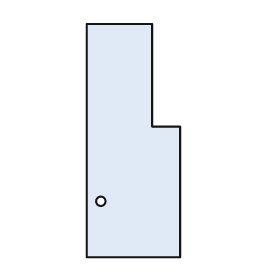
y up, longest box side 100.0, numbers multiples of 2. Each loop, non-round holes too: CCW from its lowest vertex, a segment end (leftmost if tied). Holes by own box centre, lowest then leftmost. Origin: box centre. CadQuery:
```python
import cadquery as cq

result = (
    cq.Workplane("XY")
    .moveTo(-20.0, -50.0)
    .lineTo(20.0, -50.0)
    .lineTo(20.0, 6.0)
    .lineTo(8.0, 6.0)
    .lineTo(8.0, 50.0)
    .lineTo(-20.0, 50.0)
    .close()
    .moveTo(-14.0, -26.0)
    .circle(2.0)
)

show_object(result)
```